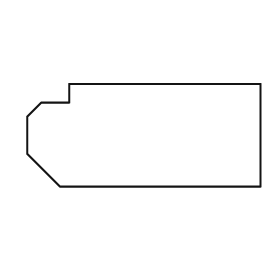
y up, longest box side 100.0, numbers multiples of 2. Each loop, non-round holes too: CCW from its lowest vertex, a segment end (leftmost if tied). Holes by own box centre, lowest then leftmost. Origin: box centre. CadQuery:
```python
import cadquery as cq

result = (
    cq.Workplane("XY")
    .moveTo(-36.0, -22.0)
    .lineTo(50.0, -22.0)
    .lineTo(50.0, 22.0)
    .lineTo(-32.0, 22.0)
    .lineTo(-32.0, 14.0)
    .lineTo(-44.0, 14.0)
    .lineTo(-50.0, 8.0)
    .lineTo(-50.0, -8.0)
    .close()
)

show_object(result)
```